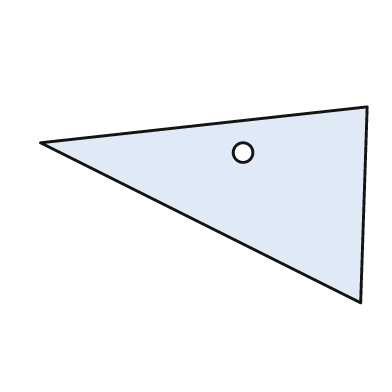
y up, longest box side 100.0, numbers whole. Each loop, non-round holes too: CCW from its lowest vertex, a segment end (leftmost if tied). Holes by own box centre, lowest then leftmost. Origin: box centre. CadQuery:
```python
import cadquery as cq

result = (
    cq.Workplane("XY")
    .moveTo(48.0, -30.0)
    .lineTo(50.0, 30.0)
    .lineTo(-50.0, 19.0)
    .close()
    .moveTo(12.0, 16.0)
    .circle(3.0)
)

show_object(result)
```